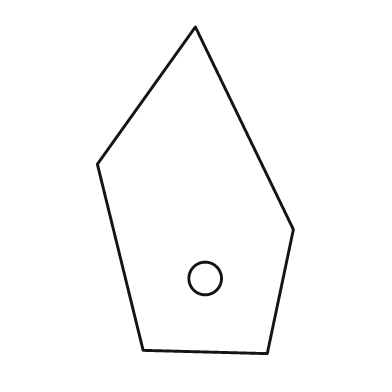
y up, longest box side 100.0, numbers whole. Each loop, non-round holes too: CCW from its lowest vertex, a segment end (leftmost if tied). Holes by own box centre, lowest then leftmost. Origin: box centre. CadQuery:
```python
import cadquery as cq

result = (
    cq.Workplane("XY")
    .moveTo(22.0, -50.0)
    .lineTo(30.0, -12.0)
    .lineTo(0.0, 50.0)
    .lineTo(-30.0, 8.0)
    .lineTo(-16.0, -49.0)
    .close()
    .moveTo(3.0, -27.0)
    .circle(5.0)
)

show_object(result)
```